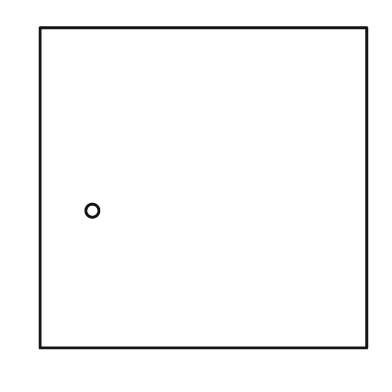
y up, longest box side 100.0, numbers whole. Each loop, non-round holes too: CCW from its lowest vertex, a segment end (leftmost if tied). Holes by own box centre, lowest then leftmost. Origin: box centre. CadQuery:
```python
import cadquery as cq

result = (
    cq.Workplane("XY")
    .moveTo(-50.0, -49.0)
    .lineTo(50.0, -49.0)
    .lineTo(50.0, 49.0)
    .lineTo(-50.0, 49.0)
    .close()
    .moveTo(-34.0, -7.0)
    .circle(2.0)
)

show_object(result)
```